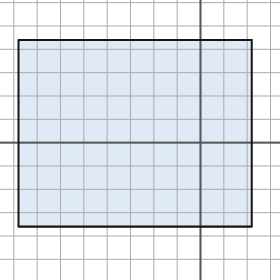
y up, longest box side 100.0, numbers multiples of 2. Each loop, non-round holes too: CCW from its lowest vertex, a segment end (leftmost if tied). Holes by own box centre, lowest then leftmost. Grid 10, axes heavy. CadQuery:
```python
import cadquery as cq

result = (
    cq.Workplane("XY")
    .moveTo(-78.0, -36.0)
    .lineTo(22.0, -36.0)
    .lineTo(22.0, 44.0)
    .lineTo(-78.0, 44.0)
    .close()
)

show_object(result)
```